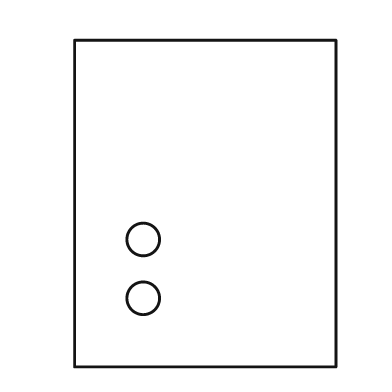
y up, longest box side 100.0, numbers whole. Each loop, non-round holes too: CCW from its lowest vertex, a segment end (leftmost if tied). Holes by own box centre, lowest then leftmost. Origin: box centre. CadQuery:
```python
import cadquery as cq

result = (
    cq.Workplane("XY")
    .moveTo(-40.0, -50.0)
    .lineTo(40.0, -50.0)
    .lineTo(40.0, 50.0)
    .lineTo(-40.0, 50.0)
    .close()
    .moveTo(-19.0, -29.0)
    .circle(5.0)
    .moveTo(-19.0, -11.0)
    .circle(5.0)
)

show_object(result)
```